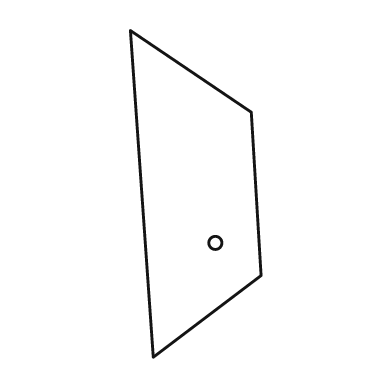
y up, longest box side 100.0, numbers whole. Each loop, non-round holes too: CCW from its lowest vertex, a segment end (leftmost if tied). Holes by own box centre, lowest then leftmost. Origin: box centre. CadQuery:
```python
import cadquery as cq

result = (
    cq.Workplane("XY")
    .moveTo(-13.0, -50.0)
    .lineTo(20.0, -25.0)
    .lineTo(17.0, 25.0)
    .lineTo(-20.0, 50.0)
    .close()
    .moveTo(6.0, -15.0)
    .circle(2.0)
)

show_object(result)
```